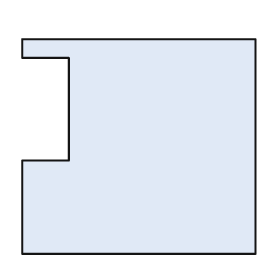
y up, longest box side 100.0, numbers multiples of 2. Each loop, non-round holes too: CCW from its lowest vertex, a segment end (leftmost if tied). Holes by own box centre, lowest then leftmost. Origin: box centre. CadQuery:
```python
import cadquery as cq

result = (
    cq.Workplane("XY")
    .moveTo(-50.0, -46.0)
    .lineTo(50.0, -46.0)
    .lineTo(50.0, 46.0)
    .lineTo(-50.0, 46.0)
    .lineTo(-50.0, 38.0)
    .lineTo(-30.0, 38.0)
    .lineTo(-30.0, -6.0)
    .lineTo(-50.0, -6.0)
    .close()
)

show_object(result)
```